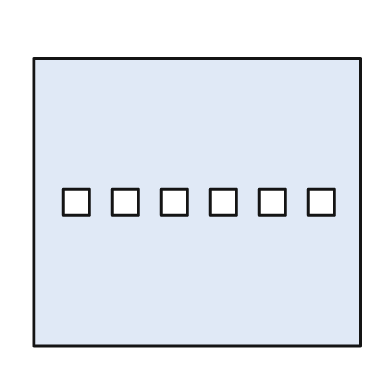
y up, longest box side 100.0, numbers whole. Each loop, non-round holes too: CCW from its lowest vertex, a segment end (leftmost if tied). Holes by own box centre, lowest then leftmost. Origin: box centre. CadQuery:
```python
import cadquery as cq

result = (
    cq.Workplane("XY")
    .moveTo(-50.0, -44.0)
    .lineTo(50.0, -44.0)
    .lineTo(50.0, 44.0)
    .lineTo(-50.0, 44.0)
    .close()
    .moveTo(-41.0, -4.0)
    .lineTo(-33.0, -4.0)
    .lineTo(-33.0, 4.0)
    .lineTo(-41.0, 4.0)
    .close()
    .moveTo(-26.0, -4.0)
    .lineTo(-18.0, -4.0)
    .lineTo(-18.0, 4.0)
    .lineTo(-26.0, 4.0)
    .close()
    .moveTo(-11.0, -4.0)
    .lineTo(-3.0, -4.0)
    .lineTo(-3.0, 4.0)
    .lineTo(-11.0, 4.0)
    .close()
    .moveTo(4.0, -4.0)
    .lineTo(12.0, -4.0)
    .lineTo(12.0, 4.0)
    .lineTo(4.0, 4.0)
    .close()
    .moveTo(19.0, -4.0)
    .lineTo(27.0, -4.0)
    .lineTo(27.0, 4.0)
    .lineTo(19.0, 4.0)
    .close()
    .moveTo(34.0, -4.0)
    .lineTo(42.0, -4.0)
    .lineTo(42.0, 4.0)
    .lineTo(34.0, 4.0)
    .close()
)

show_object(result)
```